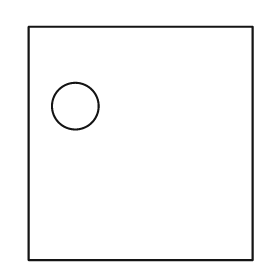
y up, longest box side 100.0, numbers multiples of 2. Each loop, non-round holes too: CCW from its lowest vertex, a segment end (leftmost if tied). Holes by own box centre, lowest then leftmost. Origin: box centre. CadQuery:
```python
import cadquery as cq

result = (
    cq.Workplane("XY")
    .moveTo(-48.0, -50.0)
    .lineTo(48.0, -50.0)
    .lineTo(48.0, 50.0)
    .lineTo(-48.0, 50.0)
    .close()
    .moveTo(-28.0, 16.0)
    .circle(10.0)
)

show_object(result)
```